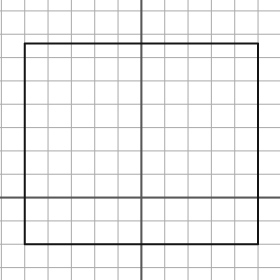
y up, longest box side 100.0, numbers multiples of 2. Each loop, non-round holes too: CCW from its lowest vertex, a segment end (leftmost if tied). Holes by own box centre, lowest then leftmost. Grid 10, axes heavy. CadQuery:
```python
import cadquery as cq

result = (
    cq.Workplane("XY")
    .moveTo(-50.0, -20.0)
    .lineTo(50.0, -20.0)
    .lineTo(50.0, 66.0)
    .lineTo(-50.0, 66.0)
    .close()
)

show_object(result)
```